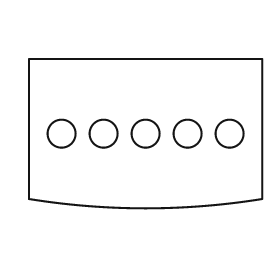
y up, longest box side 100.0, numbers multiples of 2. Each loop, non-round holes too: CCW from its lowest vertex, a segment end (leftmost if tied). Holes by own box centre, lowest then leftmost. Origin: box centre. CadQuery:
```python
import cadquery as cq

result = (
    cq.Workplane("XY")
    .moveTo(-50.0, -28.0)
    .threePointArc((0.0, -32.0), (50.0, -28.0))
    .lineTo(50.0, 32.0)
    .lineTo(-50.0, 32.0)
    .close()
    .moveTo(-36.0, 0.0)
    .circle(6.0)
    .moveTo(-18.0, 0.0)
    .circle(6.0)
    .moveTo(0.0, 0.0)
    .circle(6.0)
    .moveTo(18.0, 0.0)
    .circle(6.0)
    .moveTo(36.0, 0.0)
    .circle(6.0)
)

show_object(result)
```